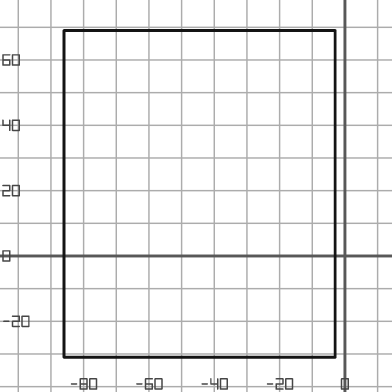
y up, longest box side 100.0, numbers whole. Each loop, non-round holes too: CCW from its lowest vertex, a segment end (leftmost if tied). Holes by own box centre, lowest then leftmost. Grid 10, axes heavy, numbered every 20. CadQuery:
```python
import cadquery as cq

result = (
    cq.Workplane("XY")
    .moveTo(-86.0, -31.0)
    .lineTo(-3.0, -31.0)
    .lineTo(-3.0, 69.0)
    .lineTo(-86.0, 69.0)
    .close()
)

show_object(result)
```